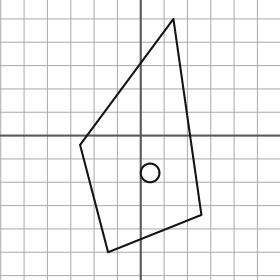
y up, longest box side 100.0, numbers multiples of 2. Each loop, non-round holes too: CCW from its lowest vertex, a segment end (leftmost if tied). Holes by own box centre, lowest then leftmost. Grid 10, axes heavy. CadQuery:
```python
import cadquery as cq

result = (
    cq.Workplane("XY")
    .moveTo(-14.0, -50.0)
    .lineTo(26.0, -34.0)
    .lineTo(14.0, 50.0)
    .lineTo(-26.0, -4.0)
    .close()
    .moveTo(4.0, -16.0)
    .circle(4.0)
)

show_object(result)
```